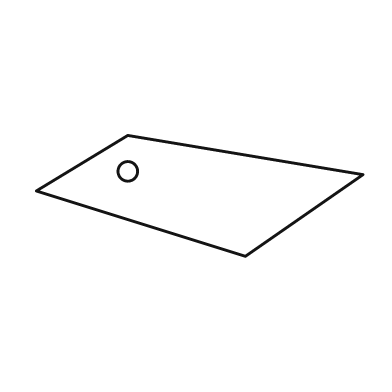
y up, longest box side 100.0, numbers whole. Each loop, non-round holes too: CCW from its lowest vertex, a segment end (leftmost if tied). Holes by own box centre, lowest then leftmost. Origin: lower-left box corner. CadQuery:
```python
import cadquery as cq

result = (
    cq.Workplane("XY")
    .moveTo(64.0, 0.0)
    .lineTo(100.0, 25.0)
    .lineTo(28.0, 37.0)
    .lineTo(0.0, 20.0)
    .close()
    .moveTo(28.0, 26.0)
    .circle(3.0)
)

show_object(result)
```